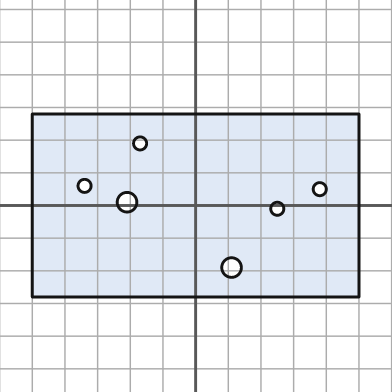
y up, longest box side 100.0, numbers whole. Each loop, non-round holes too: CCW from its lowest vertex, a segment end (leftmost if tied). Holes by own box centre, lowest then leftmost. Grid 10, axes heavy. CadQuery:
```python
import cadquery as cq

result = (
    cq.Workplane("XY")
    .moveTo(-50.0, -28.0)
    .lineTo(50.0, -28.0)
    .lineTo(50.0, 28.0)
    .lineTo(-50.0, 28.0)
    .close()
    .moveTo(11.0, -19.0)
    .circle(3.0)
    .moveTo(25.0, -1.0)
    .circle(2.0)
    .moveTo(-21.0, 1.0)
    .circle(3.0)
    .moveTo(38.0, 5.0)
    .circle(2.0)
    .moveTo(-34.0, 6.0)
    .circle(2.0)
    .moveTo(-17.0, 19.0)
    .circle(2.0)
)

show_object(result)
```